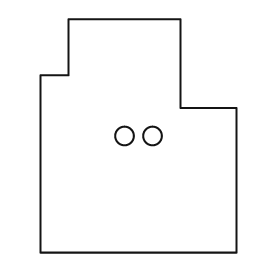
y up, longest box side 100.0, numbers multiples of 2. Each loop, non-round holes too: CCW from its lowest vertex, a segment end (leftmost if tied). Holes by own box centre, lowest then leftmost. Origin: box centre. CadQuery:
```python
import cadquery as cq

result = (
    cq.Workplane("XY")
    .moveTo(-42.0, -50.0)
    .lineTo(42.0, -50.0)
    .lineTo(42.0, 12.0)
    .lineTo(18.0, 12.0)
    .lineTo(18.0, 50.0)
    .lineTo(-30.0, 50.0)
    .lineTo(-30.0, 26.0)
    .lineTo(-42.0, 26.0)
    .close()
    .moveTo(-6.0, 0.0)
    .circle(4.0)
    .moveTo(6.0, 0.0)
    .circle(4.0)
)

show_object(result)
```